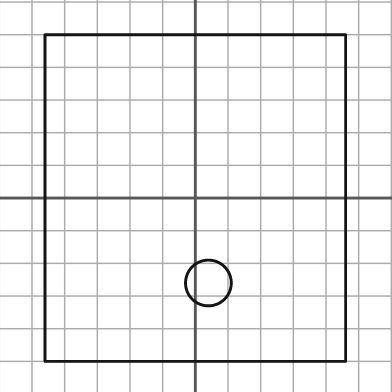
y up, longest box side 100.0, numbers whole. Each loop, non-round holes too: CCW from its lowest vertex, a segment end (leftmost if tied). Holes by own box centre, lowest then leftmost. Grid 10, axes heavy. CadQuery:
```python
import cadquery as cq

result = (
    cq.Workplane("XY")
    .moveTo(-46.0, -50.0)
    .lineTo(46.0, -50.0)
    .lineTo(46.0, 50.0)
    .lineTo(-46.0, 50.0)
    .close()
    .moveTo(4.0, -26.0)
    .circle(7.0)
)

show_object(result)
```